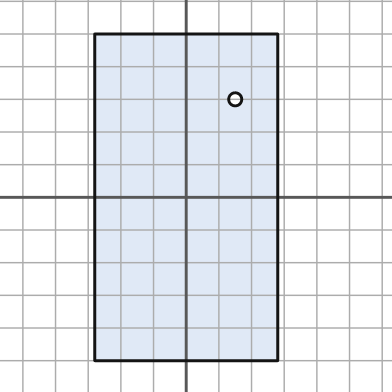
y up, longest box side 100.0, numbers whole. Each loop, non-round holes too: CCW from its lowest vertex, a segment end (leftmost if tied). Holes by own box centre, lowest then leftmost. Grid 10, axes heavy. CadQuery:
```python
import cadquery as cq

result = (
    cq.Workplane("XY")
    .moveTo(-28.0, -50.0)
    .lineTo(28.0, -50.0)
    .lineTo(28.0, 50.0)
    .lineTo(-28.0, 50.0)
    .close()
    .moveTo(15.0, 30.0)
    .circle(2.0)
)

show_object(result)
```